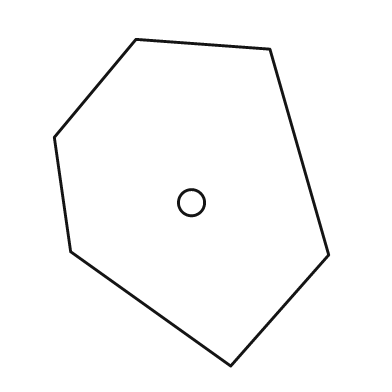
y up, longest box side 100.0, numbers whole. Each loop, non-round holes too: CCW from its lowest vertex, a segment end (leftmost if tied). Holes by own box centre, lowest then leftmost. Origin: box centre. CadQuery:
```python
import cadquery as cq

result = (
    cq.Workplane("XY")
    .moveTo(12.0, -50.0)
    .lineTo(42.0, -16.0)
    .lineTo(24.0, 47.0)
    .lineTo(-17.0, 50.0)
    .lineTo(-42.0, 20.0)
    .lineTo(-37.0, -15.0)
    .close()
    .moveTo(0.0, 0.0)
    .circle(4.0)
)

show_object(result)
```